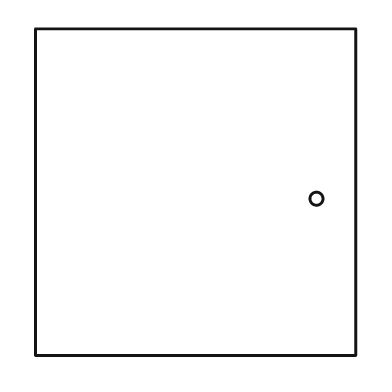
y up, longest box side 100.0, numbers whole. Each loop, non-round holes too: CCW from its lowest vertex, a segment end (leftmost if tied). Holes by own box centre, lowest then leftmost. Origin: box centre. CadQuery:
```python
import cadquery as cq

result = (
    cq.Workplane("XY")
    .moveTo(-49.0, -50.0)
    .lineTo(49.0, -50.0)
    .lineTo(49.0, 50.0)
    .lineTo(-49.0, 50.0)
    .close()
    .moveTo(37.0, -2.0)
    .circle(2.0)
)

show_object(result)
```